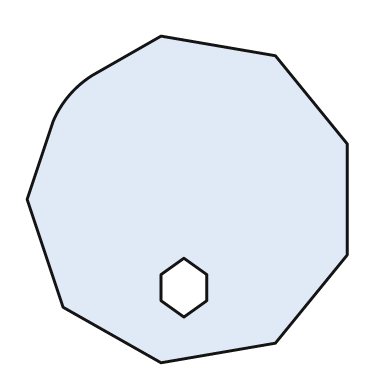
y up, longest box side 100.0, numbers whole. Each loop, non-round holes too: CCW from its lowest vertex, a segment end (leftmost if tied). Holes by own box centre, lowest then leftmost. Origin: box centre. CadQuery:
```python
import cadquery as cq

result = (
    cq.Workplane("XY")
    .moveTo(-8.0, -50.0)
    .lineTo(27.0, -44.0)
    .lineTo(49.0, -17.0)
    .lineTo(49.0, 17.0)
    .lineTo(27.0, 44.0)
    .lineTo(-8.0, 50.0)
    .lineTo(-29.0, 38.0)
    .threePointArc((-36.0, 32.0), (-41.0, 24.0))
    .lineTo(-49.0, 0.0)
    .lineTo(-38.0, -33.0)
    .close()
    .moveTo(-1.0, -36.0)
    .lineTo(6.0, -31.0)
    .lineTo(6.0, -23.0)
    .lineTo(-1.0, -18.0)
    .lineTo(-8.0, -23.0)
    .lineTo(-8.0, -31.0)
    .close()
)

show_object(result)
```